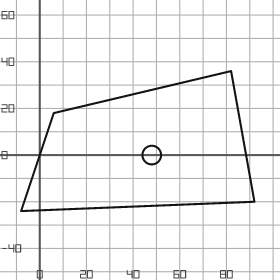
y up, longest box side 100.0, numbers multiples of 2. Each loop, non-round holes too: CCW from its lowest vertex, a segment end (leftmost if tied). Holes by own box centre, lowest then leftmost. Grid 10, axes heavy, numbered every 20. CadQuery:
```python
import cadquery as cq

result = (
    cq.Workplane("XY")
    .moveTo(-8.0, -24.0)
    .lineTo(92.0, -20.0)
    .lineTo(82.0, 36.0)
    .lineTo(6.0, 18.0)
    .close()
    .moveTo(48.0, 0.0)
    .circle(4.0)
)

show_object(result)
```